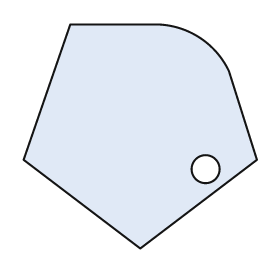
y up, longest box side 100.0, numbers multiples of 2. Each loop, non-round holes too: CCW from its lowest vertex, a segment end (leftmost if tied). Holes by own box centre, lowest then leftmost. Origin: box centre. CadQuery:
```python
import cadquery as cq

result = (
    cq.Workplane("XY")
    .moveTo(0.0, -48.0)
    .lineTo(50.0, -10.0)
    .lineTo(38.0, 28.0)
    .threePointArc((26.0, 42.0), (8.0, 48.0))
    .lineTo(-30.0, 48.0)
    .lineTo(-50.0, -10.0)
    .close()
    .moveTo(28.0, -14.0)
    .circle(6.0)
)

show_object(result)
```